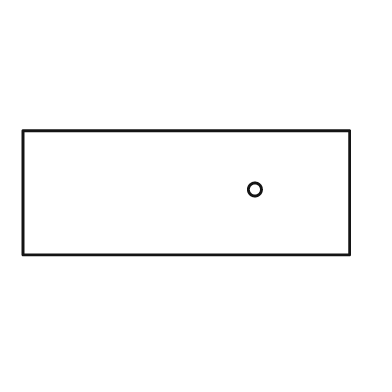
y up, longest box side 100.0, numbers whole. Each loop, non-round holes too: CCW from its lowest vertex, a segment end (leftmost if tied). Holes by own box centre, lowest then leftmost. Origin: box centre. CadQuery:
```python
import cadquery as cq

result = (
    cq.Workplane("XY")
    .moveTo(-50.0, -19.0)
    .lineTo(50.0, -19.0)
    .lineTo(50.0, 19.0)
    .lineTo(-50.0, 19.0)
    .close()
    .moveTo(21.0, 1.0)
    .circle(2.0)
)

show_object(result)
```